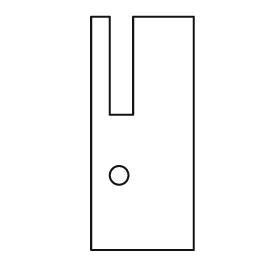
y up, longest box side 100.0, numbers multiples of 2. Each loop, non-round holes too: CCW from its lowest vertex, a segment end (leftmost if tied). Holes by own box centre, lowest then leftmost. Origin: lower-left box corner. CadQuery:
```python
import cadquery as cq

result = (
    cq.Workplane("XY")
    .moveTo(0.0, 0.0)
    .lineTo(44.0, 0.0)
    .lineTo(44.0, 100.0)
    .lineTo(18.0, 100.0)
    .lineTo(18.0, 58.0)
    .lineTo(8.0, 58.0)
    .lineTo(8.0, 100.0)
    .lineTo(0.0, 100.0)
    .close()
    .moveTo(12.0, 32.0)
    .circle(4.0)
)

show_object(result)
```